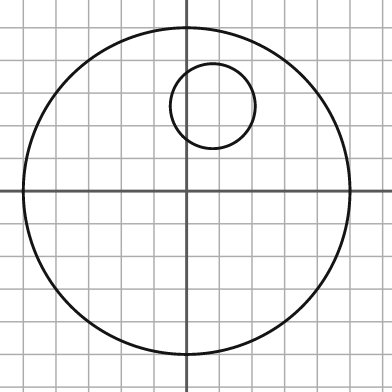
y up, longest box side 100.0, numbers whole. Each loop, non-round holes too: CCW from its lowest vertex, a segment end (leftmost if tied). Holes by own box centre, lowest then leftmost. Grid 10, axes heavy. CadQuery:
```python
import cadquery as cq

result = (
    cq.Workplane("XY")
    .moveTo(0.0, 0.0)
    .circle(50.0)
    .moveTo(8.0, 26.0)
    .circle(13.0)
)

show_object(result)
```